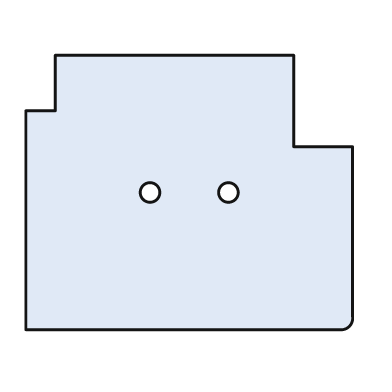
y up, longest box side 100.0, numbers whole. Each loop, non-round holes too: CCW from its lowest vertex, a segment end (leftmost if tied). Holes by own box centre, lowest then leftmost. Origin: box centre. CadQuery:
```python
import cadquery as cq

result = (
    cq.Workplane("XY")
    .moveTo(-50.0, -42.0)
    .lineTo(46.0, -42.0)
    .threePointArc((49.0, -41.0), (50.0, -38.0))
    .lineTo(50.0, 14.0)
    .lineTo(32.0, 14.0)
    .lineTo(32.0, 42.0)
    .lineTo(-41.0, 42.0)
    .lineTo(-41.0, 25.0)
    .lineTo(-50.0, 25.0)
    .close()
    .moveTo(-12.0, 0.0)
    .circle(3.0)
    .moveTo(12.0, 0.0)
    .circle(3.0)
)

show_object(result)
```